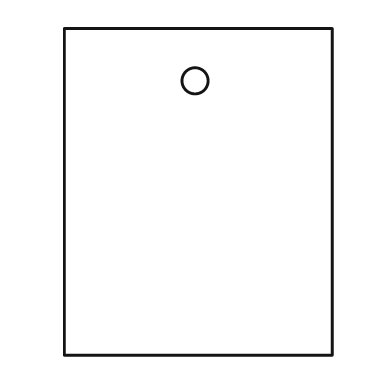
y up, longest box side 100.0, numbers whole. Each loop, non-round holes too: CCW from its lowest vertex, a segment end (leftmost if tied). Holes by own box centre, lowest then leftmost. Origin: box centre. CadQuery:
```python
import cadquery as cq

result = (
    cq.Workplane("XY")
    .moveTo(-41.0, -50.0)
    .lineTo(41.0, -50.0)
    .lineTo(41.0, 50.0)
    .lineTo(-41.0, 50.0)
    .close()
    .moveTo(-1.0, 34.0)
    .circle(4.0)
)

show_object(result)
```